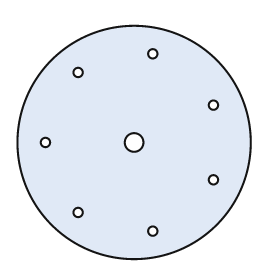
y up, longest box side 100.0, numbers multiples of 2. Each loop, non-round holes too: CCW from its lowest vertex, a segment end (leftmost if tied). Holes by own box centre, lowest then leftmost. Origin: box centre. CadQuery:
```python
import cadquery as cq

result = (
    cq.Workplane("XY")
    .moveTo(0.0, 0.0)
    .circle(50.0)
    .moveTo(8.0, -38.0)
    .circle(2.0)
    .moveTo(-24.0, -30.0)
    .circle(2.0)
    .moveTo(34.0, -16.0)
    .circle(2.0)
    .moveTo(-38.0, 0.0)
    .circle(2.0)
    .moveTo(0.0, 0.0)
    .circle(4.0)
    .moveTo(34.0, 16.0)
    .circle(2.0)
    .moveTo(-24.0, 30.0)
    .circle(2.0)
    .moveTo(8.0, 38.0)
    .circle(2.0)
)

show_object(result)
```